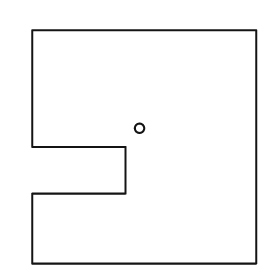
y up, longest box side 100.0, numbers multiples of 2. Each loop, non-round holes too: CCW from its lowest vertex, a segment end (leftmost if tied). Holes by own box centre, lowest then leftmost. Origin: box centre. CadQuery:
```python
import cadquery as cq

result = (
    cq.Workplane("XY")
    .moveTo(-48.0, -50.0)
    .lineTo(48.0, -50.0)
    .lineTo(48.0, 50.0)
    .lineTo(-48.0, 50.0)
    .lineTo(-48.0, 0.0)
    .lineTo(-8.0, 0.0)
    .lineTo(-8.0, -20.0)
    .lineTo(-48.0, -20.0)
    .close()
    .moveTo(-2.0, 8.0)
    .circle(2.0)
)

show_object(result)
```